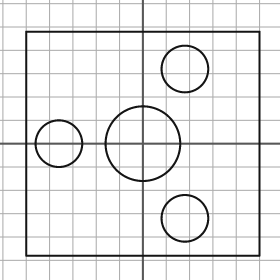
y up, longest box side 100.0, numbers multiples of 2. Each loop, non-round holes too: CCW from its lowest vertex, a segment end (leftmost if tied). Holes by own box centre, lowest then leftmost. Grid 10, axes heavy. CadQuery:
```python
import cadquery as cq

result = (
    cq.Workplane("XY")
    .moveTo(-50.0, -48.0)
    .lineTo(50.0, -48.0)
    .lineTo(50.0, 48.0)
    .lineTo(-50.0, 48.0)
    .close()
    .moveTo(18.0, -32.0)
    .circle(10.0)
    .moveTo(-36.0, 0.0)
    .circle(10.0)
    .moveTo(0.0, 0.0)
    .circle(16.0)
    .moveTo(18.0, 32.0)
    .circle(10.0)
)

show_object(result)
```